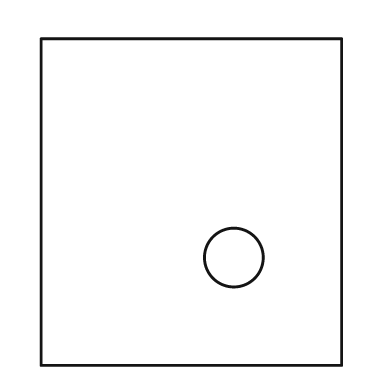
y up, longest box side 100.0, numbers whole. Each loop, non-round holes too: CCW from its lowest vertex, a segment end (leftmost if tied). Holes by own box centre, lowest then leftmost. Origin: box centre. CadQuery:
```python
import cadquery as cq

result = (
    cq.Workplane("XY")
    .moveTo(-46.0, -50.0)
    .lineTo(46.0, -50.0)
    .lineTo(46.0, 50.0)
    .lineTo(-46.0, 50.0)
    .close()
    .moveTo(13.0, -17.0)
    .circle(9.0)
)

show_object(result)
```